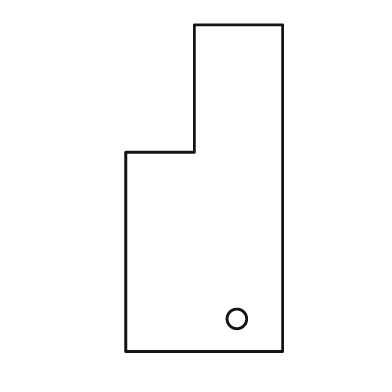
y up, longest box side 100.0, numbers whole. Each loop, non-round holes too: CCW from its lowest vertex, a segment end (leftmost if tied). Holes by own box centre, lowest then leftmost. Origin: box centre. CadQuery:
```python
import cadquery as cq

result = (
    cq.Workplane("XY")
    .moveTo(-24.0, -50.0)
    .lineTo(24.0, -50.0)
    .lineTo(24.0, 50.0)
    .lineTo(-3.0, 50.0)
    .lineTo(-3.0, 11.0)
    .lineTo(-24.0, 11.0)
    .close()
    .moveTo(10.0, -40.0)
    .circle(3.0)
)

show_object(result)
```